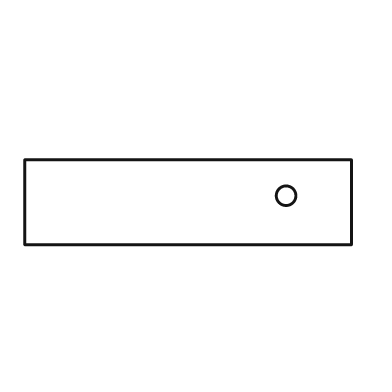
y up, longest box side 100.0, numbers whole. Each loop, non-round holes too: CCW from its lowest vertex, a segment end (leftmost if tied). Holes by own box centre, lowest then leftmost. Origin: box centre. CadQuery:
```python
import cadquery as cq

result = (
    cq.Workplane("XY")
    .moveTo(-50.0, -13.0)
    .lineTo(50.0, -13.0)
    .lineTo(50.0, 13.0)
    .lineTo(-50.0, 13.0)
    .close()
    .moveTo(30.0, 2.0)
    .circle(3.0)
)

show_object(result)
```